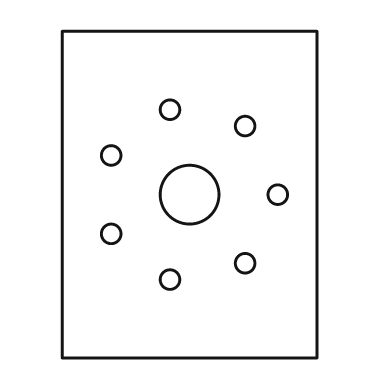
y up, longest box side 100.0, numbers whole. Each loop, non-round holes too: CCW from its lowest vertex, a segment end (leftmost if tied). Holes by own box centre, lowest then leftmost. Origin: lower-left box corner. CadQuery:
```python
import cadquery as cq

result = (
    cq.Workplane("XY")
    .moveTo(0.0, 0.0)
    .lineTo(78.0, 0.0)
    .lineTo(78.0, 100.0)
    .lineTo(0.0, 100.0)
    .close()
    .moveTo(33.0, 24.0)
    .circle(3.0)
    .moveTo(56.0, 29.0)
    .circle(3.0)
    .moveTo(15.0, 38.0)
    .circle(3.0)
    .moveTo(39.0, 50.0)
    .circle(9.0)
    .moveTo(66.0, 50.0)
    .circle(3.0)
    .moveTo(15.0, 62.0)
    .circle(3.0)
    .moveTo(56.0, 71.0)
    .circle(3.0)
    .moveTo(33.0, 76.0)
    .circle(3.0)
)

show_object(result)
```